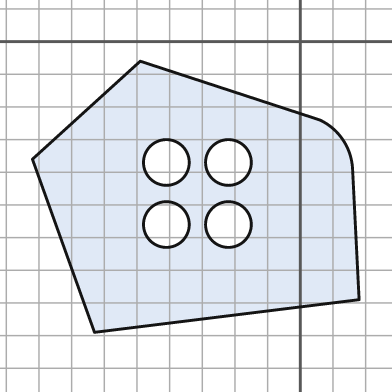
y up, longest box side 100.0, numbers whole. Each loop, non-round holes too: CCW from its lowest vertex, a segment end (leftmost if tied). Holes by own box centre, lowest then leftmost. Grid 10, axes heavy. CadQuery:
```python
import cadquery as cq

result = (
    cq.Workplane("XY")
    .moveTo(-63.0, -89.0)
    .lineTo(18.0, -79.0)
    .lineTo(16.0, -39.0)
    .threePointArc((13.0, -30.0), (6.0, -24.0))
    .lineTo(-49.0, -6.0)
    .lineTo(-82.0, -36.0)
    .close()
    .moveTo(-41.0, -56.0)
    .circle(7.0)
    .moveTo(-22.0, -56.0)
    .circle(7.0)
    .moveTo(-41.0, -37.0)
    .circle(7.0)
    .moveTo(-22.0, -37.0)
    .circle(7.0)
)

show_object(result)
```